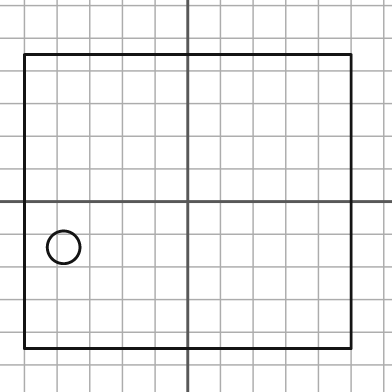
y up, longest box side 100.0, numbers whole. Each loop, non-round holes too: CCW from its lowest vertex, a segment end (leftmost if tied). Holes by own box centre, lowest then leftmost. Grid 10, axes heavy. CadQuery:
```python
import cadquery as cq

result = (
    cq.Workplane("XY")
    .moveTo(-50.0, -45.0)
    .lineTo(50.0, -45.0)
    .lineTo(50.0, 45.0)
    .lineTo(-50.0, 45.0)
    .close()
    .moveTo(-38.0, -14.0)
    .circle(5.0)
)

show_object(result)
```